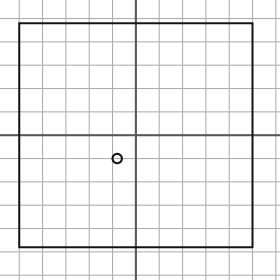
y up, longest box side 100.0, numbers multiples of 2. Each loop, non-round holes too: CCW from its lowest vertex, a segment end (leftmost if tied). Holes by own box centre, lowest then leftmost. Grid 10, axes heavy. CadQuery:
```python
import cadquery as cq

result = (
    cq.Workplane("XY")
    .moveTo(-50.0, -48.0)
    .lineTo(50.0, -48.0)
    .lineTo(50.0, 48.0)
    .lineTo(-50.0, 48.0)
    .close()
    .moveTo(-8.0, -10.0)
    .circle(2.0)
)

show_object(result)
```